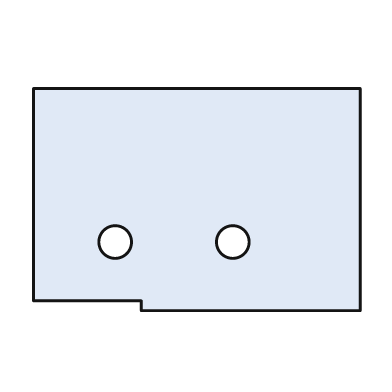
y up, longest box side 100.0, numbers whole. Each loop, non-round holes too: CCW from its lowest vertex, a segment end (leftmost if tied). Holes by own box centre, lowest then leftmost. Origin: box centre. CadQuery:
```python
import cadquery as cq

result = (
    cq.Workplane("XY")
    .moveTo(-17.0, -34.0)
    .lineTo(50.0, -34.0)
    .lineTo(50.0, 34.0)
    .lineTo(-50.0, 34.0)
    .lineTo(-50.0, -31.0)
    .lineTo(-17.0, -31.0)
    .close()
    .moveTo(-25.0, -13.0)
    .circle(5.0)
    .moveTo(11.0, -13.0)
    .circle(5.0)
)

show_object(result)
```